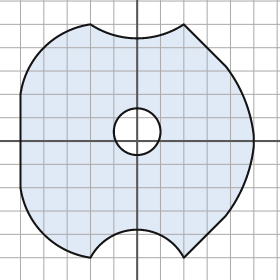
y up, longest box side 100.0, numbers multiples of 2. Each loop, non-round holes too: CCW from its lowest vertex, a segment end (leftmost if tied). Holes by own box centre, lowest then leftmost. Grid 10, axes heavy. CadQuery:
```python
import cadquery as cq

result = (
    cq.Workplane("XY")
    .moveTo(-20.0, -50.0)
    .threePointArc((0.0, -38.0), (20.0, -50.0))
    .lineTo(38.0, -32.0)
    .threePointArc((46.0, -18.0), (50.0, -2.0))
    .lineTo(50.0, 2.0)
    .threePointArc((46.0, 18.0), (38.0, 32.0))
    .lineTo(20.0, 50.0)
    .threePointArc((0.0, 44.0), (-20.0, 50.0))
    .threePointArc((-40.0, 40.0), (-50.0, 20.0))
    .lineTo(-50.0, -20.0)
    .threePointArc((-40.0, -40.0), (-20.0, -50.0))
    .close()
    .moveTo(0.0, 4.0)
    .circle(10.0)
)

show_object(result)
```